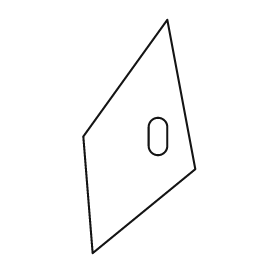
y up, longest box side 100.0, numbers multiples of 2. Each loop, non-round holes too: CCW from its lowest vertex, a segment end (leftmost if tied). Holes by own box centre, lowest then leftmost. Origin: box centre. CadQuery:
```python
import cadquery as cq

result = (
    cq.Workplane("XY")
    .moveTo(-20.0, -50.0)
    .lineTo(24.0, -14.0)
    .lineTo(12.0, 50.0)
    .lineTo(-24.0, 0.0)
    .close()
    .moveTo(4.0, -4.0)
    .threePointArc((8.0, -8.0), (12.0, -4.0))
    .lineTo(12.0, 4.0)
    .threePointArc((8.0, 8.0), (4.0, 4.0))
    .close()
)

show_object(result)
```